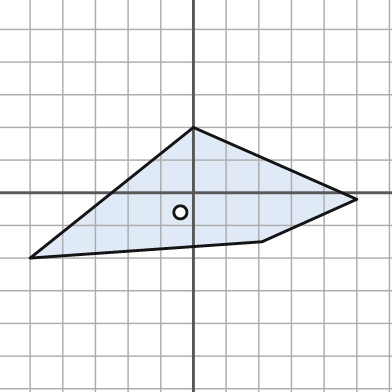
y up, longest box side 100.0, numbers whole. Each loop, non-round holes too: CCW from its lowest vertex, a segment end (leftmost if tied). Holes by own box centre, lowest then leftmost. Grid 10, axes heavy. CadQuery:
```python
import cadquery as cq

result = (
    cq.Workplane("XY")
    .moveTo(-50.0, -20.0)
    .lineTo(21.0, -15.0)
    .lineTo(50.0, -2.0)
    .lineTo(0.0, 20.0)
    .close()
    .moveTo(-4.0, -6.0)
    .circle(2.0)
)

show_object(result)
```